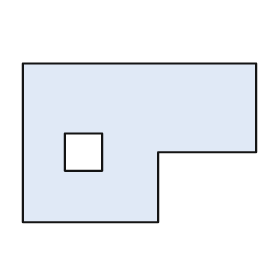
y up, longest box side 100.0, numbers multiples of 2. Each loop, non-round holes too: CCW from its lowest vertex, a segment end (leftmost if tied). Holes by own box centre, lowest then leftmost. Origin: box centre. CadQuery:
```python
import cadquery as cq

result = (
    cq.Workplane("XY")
    .moveTo(-50.0, -34.0)
    .lineTo(8.0, -34.0)
    .lineTo(8.0, -4.0)
    .lineTo(50.0, -4.0)
    .lineTo(50.0, 34.0)
    .lineTo(-50.0, 34.0)
    .close()
    .moveTo(-32.0, -12.0)
    .lineTo(-16.0, -12.0)
    .lineTo(-16.0, 4.0)
    .lineTo(-32.0, 4.0)
    .close()
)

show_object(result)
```